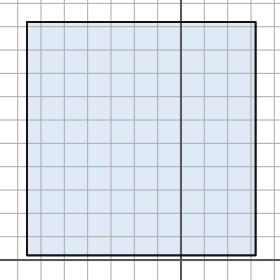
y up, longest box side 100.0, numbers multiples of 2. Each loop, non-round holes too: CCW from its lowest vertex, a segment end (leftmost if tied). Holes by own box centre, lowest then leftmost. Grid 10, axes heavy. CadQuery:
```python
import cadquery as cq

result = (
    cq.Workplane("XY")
    .moveTo(-66.0, 2.0)
    .lineTo(32.0, 2.0)
    .lineTo(32.0, 102.0)
    .lineTo(-66.0, 102.0)
    .close()
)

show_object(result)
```